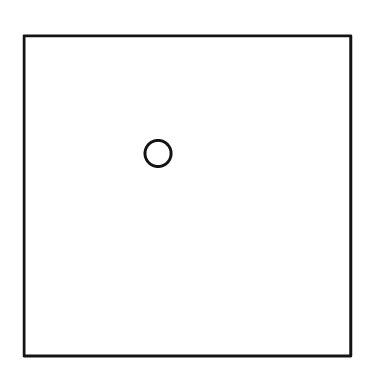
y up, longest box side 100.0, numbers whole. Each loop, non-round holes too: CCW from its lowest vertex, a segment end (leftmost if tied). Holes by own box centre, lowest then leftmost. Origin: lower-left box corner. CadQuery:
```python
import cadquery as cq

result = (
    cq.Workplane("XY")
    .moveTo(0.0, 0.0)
    .lineTo(100.0, 0.0)
    .lineTo(100.0, 98.0)
    .lineTo(0.0, 98.0)
    .close()
    .moveTo(41.0, 62.0)
    .circle(4.0)
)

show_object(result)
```